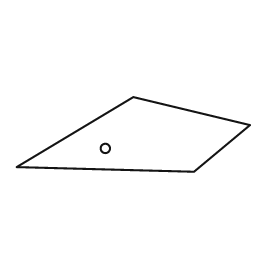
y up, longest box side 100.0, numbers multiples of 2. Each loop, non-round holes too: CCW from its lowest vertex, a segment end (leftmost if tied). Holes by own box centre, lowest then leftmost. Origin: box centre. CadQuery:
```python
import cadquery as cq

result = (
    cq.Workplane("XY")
    .moveTo(26.0, -16.0)
    .lineTo(50.0, 4.0)
    .lineTo(0.0, 16.0)
    .lineTo(-50.0, -14.0)
    .close()
    .moveTo(-12.0, -6.0)
    .circle(2.0)
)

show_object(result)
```